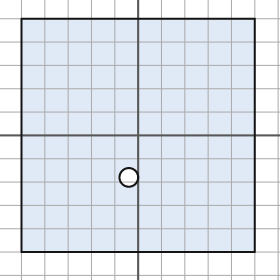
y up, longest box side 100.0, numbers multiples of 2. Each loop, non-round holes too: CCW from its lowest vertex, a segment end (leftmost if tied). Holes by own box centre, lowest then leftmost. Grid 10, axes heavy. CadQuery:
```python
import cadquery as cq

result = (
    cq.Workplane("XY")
    .moveTo(-50.0, -50.0)
    .lineTo(50.0, -50.0)
    .lineTo(50.0, 50.0)
    .lineTo(-50.0, 50.0)
    .close()
    .moveTo(-4.0, -18.0)
    .circle(4.0)
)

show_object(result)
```